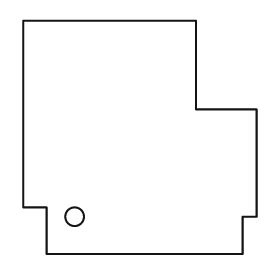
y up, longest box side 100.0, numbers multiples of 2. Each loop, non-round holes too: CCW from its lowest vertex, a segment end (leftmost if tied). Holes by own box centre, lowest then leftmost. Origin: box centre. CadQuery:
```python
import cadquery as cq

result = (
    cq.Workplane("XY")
    .moveTo(-40.0, -50.0)
    .lineTo(44.0, -50.0)
    .lineTo(44.0, -34.0)
    .lineTo(50.0, -34.0)
    .lineTo(50.0, 12.0)
    .lineTo(24.0, 12.0)
    .lineTo(24.0, 50.0)
    .lineTo(-50.0, 50.0)
    .lineTo(-50.0, -30.0)
    .lineTo(-40.0, -30.0)
    .close()
    .moveTo(-28.0, -34.0)
    .circle(4.0)
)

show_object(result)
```